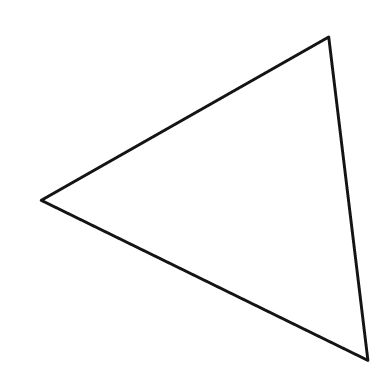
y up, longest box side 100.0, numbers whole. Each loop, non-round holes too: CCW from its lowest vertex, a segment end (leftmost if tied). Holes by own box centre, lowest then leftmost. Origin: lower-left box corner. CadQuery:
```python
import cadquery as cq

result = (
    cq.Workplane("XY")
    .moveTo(100.0, 0.0)
    .lineTo(88.0, 99.0)
    .lineTo(0.0, 49.0)
    .close()
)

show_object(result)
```